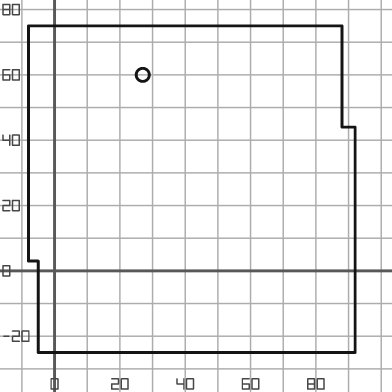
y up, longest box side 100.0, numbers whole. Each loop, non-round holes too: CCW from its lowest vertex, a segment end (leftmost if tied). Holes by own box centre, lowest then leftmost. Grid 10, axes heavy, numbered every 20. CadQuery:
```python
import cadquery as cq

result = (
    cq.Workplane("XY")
    .moveTo(-5.0, -25.0)
    .lineTo(92.0, -25.0)
    .lineTo(92.0, 44.0)
    .lineTo(88.0, 44.0)
    .lineTo(88.0, 75.0)
    .lineTo(-8.0, 75.0)
    .lineTo(-8.0, 3.0)
    .lineTo(-5.0, 3.0)
    .close()
    .moveTo(27.0, 60.0)
    .circle(2.0)
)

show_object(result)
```